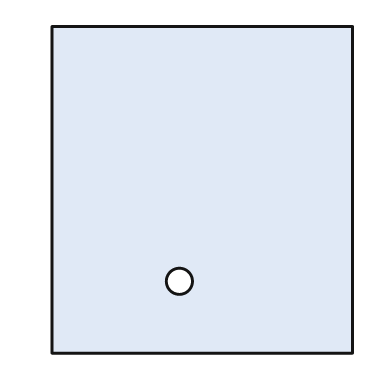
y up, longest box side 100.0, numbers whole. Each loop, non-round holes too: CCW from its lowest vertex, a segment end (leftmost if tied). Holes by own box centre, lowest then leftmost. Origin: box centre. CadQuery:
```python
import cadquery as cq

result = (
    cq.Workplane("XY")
    .moveTo(-46.0, -50.0)
    .lineTo(46.0, -50.0)
    .lineTo(46.0, 50.0)
    .lineTo(-46.0, 50.0)
    .close()
    .moveTo(-7.0, -28.0)
    .circle(4.0)
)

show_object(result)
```